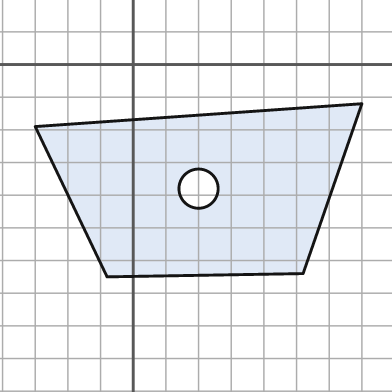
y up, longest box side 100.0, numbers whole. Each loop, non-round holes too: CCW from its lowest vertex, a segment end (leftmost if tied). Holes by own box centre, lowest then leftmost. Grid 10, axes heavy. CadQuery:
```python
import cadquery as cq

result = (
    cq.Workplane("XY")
    .moveTo(-8.0, -65.0)
    .lineTo(52.0, -64.0)
    .lineTo(70.0, -12.0)
    .lineTo(-30.0, -19.0)
    .close()
    .moveTo(20.0, -38.0)
    .circle(6.0)
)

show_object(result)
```